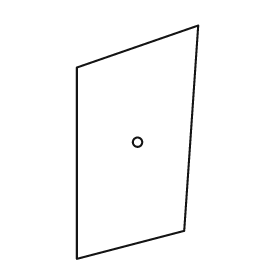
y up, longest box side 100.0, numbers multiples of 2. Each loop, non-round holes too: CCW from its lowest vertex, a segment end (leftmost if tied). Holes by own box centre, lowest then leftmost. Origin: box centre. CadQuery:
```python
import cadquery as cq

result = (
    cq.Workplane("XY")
    .moveTo(-26.0, -50.0)
    .lineTo(20.0, -38.0)
    .lineTo(26.0, 50.0)
    .lineTo(-26.0, 32.0)
    .close()
    .moveTo(0.0, 0.0)
    .circle(2.0)
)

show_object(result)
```